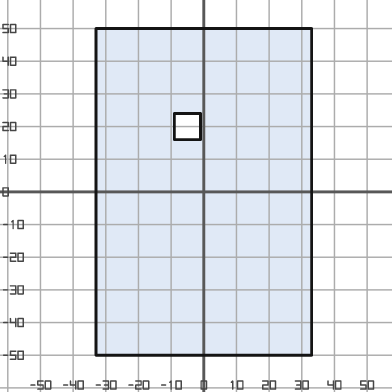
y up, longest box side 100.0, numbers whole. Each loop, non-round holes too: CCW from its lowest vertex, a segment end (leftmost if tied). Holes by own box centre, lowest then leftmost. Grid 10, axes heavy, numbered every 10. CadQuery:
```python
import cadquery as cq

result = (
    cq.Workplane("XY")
    .moveTo(-33.0, -50.0)
    .lineTo(33.0, -50.0)
    .lineTo(33.0, 50.0)
    .lineTo(-33.0, 50.0)
    .close()
    .moveTo(-9.0, 16.0)
    .lineTo(-1.0, 16.0)
    .lineTo(-1.0, 24.0)
    .lineTo(-9.0, 24.0)
    .close()
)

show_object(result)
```